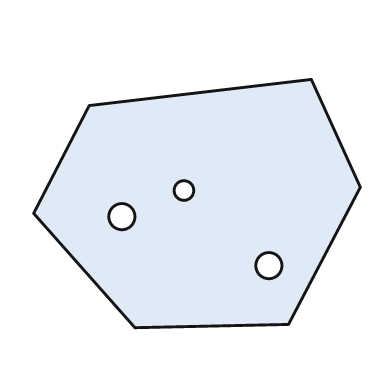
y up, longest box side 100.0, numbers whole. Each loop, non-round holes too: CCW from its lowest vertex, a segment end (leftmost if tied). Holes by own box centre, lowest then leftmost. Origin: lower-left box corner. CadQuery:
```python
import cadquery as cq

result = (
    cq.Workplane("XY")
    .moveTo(31.0, 0.0)
    .lineTo(78.0, 1.0)
    .lineTo(100.0, 43.0)
    .lineTo(85.0, 76.0)
    .lineTo(17.0, 68.0)
    .lineTo(0.0, 35.0)
    .close()
    .moveTo(72.0, 19.0)
    .circle(4.0)
    .moveTo(27.0, 34.0)
    .circle(4.0)
    .moveTo(46.0, 42.0)
    .circle(3.0)
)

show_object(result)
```